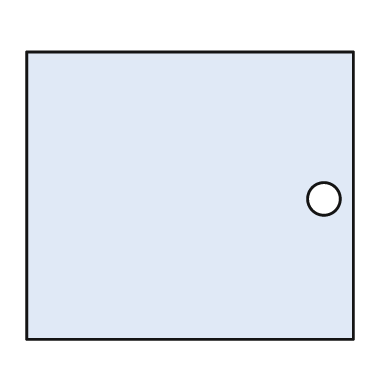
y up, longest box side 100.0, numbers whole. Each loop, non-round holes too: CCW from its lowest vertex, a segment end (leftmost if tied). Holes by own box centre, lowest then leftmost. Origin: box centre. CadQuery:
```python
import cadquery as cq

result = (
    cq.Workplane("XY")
    .moveTo(-50.0, -44.0)
    .lineTo(50.0, -44.0)
    .lineTo(50.0, 44.0)
    .lineTo(-50.0, 44.0)
    .close()
    .moveTo(41.0, -1.0)
    .circle(5.0)
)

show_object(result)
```